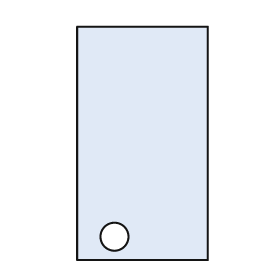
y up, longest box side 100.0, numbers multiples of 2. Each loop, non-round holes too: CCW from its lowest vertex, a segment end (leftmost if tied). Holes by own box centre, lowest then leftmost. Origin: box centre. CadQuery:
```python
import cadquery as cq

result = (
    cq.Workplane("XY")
    .moveTo(-28.0, -50.0)
    .lineTo(28.0, -50.0)
    .lineTo(28.0, 50.0)
    .lineTo(-28.0, 50.0)
    .close()
    .moveTo(-12.0, -40.0)
    .circle(6.0)
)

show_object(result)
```